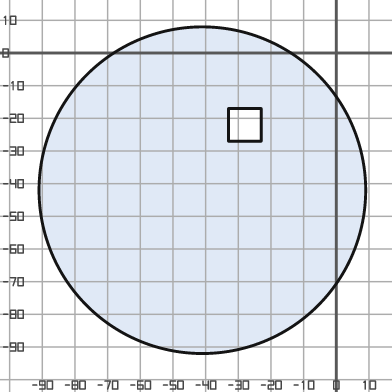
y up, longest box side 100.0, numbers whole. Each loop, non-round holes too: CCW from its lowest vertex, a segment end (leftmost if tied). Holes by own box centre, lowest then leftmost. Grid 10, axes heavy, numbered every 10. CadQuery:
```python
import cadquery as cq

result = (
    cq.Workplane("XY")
    .moveTo(-41.0, -42.0)
    .circle(50.0)
    .moveTo(-33.0, -27.0)
    .lineTo(-23.0, -27.0)
    .lineTo(-23.0, -17.0)
    .lineTo(-33.0, -17.0)
    .close()
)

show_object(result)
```